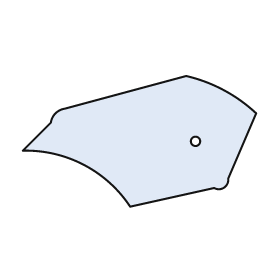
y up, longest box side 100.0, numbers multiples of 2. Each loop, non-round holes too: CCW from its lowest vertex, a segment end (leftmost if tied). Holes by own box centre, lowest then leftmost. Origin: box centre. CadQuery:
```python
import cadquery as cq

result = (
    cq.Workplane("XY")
    .moveTo(-4.0, -28.0)
    .lineTo(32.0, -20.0)
    .threePointArc((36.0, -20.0), (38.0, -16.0))
    .lineTo(50.0, 12.0)
    .threePointArc((36.0, 22.0), (20.0, 28.0))
    .lineTo(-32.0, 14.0)
    .threePointArc((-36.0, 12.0), (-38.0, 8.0))
    .lineTo(-50.0, -4.0)
    .threePointArc((-24.0, -10.0), (-4.0, -28.0))
    .close()
    .moveTo(24.0, 0.0)
    .circle(2.0)
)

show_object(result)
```